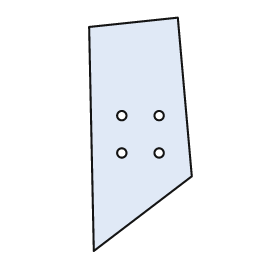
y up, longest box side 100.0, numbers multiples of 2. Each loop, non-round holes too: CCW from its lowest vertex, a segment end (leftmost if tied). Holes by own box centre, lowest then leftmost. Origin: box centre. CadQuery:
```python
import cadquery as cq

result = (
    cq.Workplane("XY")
    .moveTo(-20.0, -50.0)
    .lineTo(22.0, -18.0)
    .lineTo(16.0, 50.0)
    .lineTo(-22.0, 46.0)
    .close()
    .moveTo(-8.0, -8.0)
    .circle(2.0)
    .moveTo(8.0, -8.0)
    .circle(2.0)
    .moveTo(-8.0, 8.0)
    .circle(2.0)
    .moveTo(8.0, 8.0)
    .circle(2.0)
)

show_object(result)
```